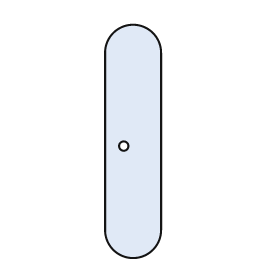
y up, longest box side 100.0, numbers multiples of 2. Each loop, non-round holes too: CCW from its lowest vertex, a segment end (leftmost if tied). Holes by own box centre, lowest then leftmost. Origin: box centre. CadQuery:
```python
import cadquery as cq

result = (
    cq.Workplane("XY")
    .moveTo(-12.0, -38.0)
    .threePointArc((0.0, -50.0), (12.0, -38.0))
    .lineTo(12.0, 38.0)
    .threePointArc((0.0, 50.0), (-12.0, 38.0))
    .close()
    .moveTo(-4.0, -2.0)
    .circle(2.0)
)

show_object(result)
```